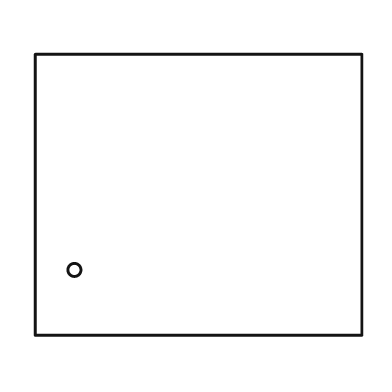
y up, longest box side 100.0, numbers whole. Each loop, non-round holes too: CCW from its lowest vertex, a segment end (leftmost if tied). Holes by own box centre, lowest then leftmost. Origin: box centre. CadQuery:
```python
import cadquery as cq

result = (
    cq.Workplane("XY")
    .moveTo(-50.0, -43.0)
    .lineTo(50.0, -43.0)
    .lineTo(50.0, 43.0)
    .lineTo(-50.0, 43.0)
    .close()
    .moveTo(-38.0, -23.0)
    .circle(2.0)
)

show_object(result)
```